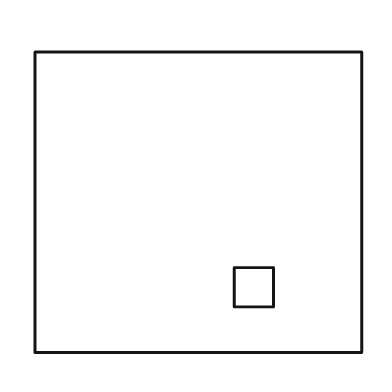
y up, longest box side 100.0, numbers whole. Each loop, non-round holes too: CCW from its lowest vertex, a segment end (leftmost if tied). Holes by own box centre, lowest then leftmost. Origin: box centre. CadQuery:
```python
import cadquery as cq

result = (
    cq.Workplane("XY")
    .moveTo(-50.0, -46.0)
    .lineTo(50.0, -46.0)
    .lineTo(50.0, 46.0)
    .lineTo(-50.0, 46.0)
    .close()
    .moveTo(11.0, -32.0)
    .lineTo(23.0, -32.0)
    .lineTo(23.0, -20.0)
    .lineTo(11.0, -20.0)
    .close()
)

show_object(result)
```